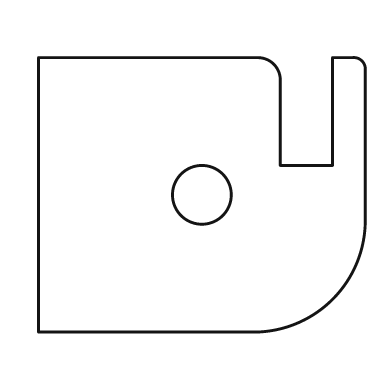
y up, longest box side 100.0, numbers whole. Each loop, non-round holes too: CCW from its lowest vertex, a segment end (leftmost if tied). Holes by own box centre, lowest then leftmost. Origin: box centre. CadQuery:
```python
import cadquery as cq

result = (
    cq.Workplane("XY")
    .moveTo(-50.0, -42.0)
    .lineTo(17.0, -42.0)
    .threePointArc((40.0, -32.0), (50.0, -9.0))
    .lineTo(50.0, 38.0)
    .threePointArc((49.0, 41.0), (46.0, 42.0))
    .lineTo(40.0, 42.0)
    .lineTo(40.0, 9.0)
    .lineTo(24.0, 9.0)
    .lineTo(24.0, 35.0)
    .threePointArc((22.0, 40.0), (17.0, 42.0))
    .lineTo(-50.0, 42.0)
    .close()
    .moveTo(0.0, 0.0)
    .circle(9.0)
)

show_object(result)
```